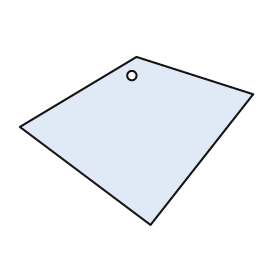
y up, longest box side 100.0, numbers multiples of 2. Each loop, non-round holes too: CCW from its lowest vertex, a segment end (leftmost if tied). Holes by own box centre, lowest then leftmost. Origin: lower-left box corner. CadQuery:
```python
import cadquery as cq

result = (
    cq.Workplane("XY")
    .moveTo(56.0, 0.0)
    .lineTo(100.0, 56.0)
    .lineTo(50.0, 72.0)
    .lineTo(0.0, 42.0)
    .close()
    .moveTo(48.0, 64.0)
    .circle(2.0)
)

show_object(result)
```